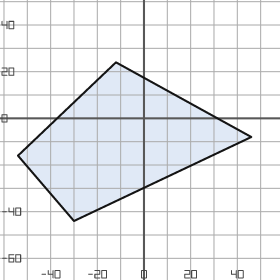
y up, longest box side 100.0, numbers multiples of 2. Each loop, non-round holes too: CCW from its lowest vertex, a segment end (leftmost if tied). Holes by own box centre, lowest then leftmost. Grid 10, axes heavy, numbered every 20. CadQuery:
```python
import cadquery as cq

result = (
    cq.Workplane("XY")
    .moveTo(-30.0, -44.0)
    .lineTo(46.0, -8.0)
    .lineTo(-12.0, 24.0)
    .lineTo(-54.0, -16.0)
    .close()
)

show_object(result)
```